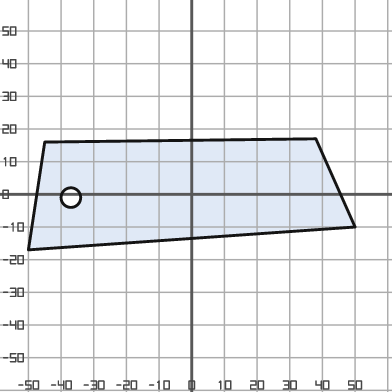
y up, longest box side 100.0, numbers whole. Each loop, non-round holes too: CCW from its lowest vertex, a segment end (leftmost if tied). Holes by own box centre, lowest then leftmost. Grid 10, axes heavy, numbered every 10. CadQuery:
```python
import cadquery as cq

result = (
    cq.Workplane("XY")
    .moveTo(-50.0, -17.0)
    .lineTo(50.0, -10.0)
    .lineTo(38.0, 17.0)
    .lineTo(-45.0, 16.0)
    .close()
    .moveTo(-37.0, -1.0)
    .circle(3.0)
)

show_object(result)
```